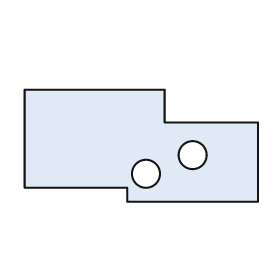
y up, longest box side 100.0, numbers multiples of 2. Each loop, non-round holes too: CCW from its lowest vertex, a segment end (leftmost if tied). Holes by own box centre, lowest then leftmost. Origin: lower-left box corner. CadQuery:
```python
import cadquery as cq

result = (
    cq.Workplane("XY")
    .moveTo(44.0, 0.0)
    .lineTo(100.0, 0.0)
    .lineTo(100.0, 34.0)
    .lineTo(60.0, 34.0)
    .lineTo(60.0, 48.0)
    .lineTo(0.0, 48.0)
    .lineTo(0.0, 6.0)
    .lineTo(44.0, 6.0)
    .close()
    .moveTo(52.0, 12.0)
    .circle(6.0)
    .moveTo(72.0, 20.0)
    .circle(6.0)
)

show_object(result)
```